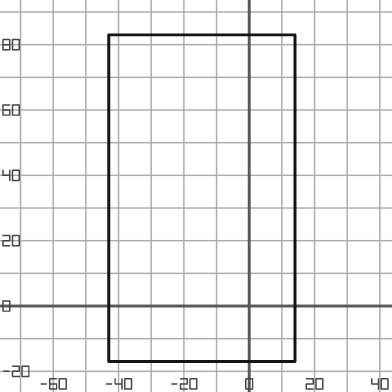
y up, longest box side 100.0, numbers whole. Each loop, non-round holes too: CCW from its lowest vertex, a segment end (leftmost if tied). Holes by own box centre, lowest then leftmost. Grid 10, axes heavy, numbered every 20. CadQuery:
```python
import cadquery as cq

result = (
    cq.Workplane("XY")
    .moveTo(-43.0, -17.0)
    .lineTo(14.0, -17.0)
    .lineTo(14.0, 83.0)
    .lineTo(-43.0, 83.0)
    .close()
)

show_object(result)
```